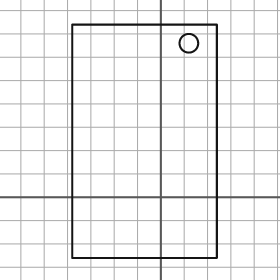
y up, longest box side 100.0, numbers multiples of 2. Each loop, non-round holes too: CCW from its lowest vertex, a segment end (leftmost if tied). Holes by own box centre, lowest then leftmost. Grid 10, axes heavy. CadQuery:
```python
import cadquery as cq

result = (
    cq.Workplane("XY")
    .moveTo(-38.0, -26.0)
    .lineTo(24.0, -26.0)
    .lineTo(24.0, 74.0)
    .lineTo(-38.0, 74.0)
    .close()
    .moveTo(12.0, 66.0)
    .circle(4.0)
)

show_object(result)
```